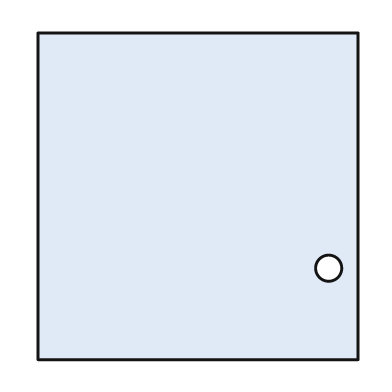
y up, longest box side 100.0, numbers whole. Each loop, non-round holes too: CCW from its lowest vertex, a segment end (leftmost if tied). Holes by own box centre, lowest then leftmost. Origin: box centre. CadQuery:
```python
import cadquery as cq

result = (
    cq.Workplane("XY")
    .moveTo(-49.0, -50.0)
    .lineTo(49.0, -50.0)
    .lineTo(49.0, 50.0)
    .lineTo(-49.0, 50.0)
    .close()
    .moveTo(40.0, -22.0)
    .circle(4.0)
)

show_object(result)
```